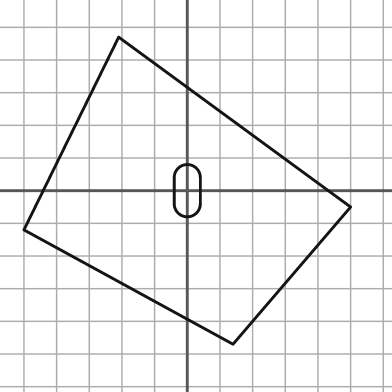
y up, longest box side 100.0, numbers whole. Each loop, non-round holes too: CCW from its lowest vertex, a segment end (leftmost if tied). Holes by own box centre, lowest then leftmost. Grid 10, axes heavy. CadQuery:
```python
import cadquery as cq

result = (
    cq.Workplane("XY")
    .moveTo(14.0, -47.0)
    .lineTo(50.0, -5.0)
    .lineTo(-21.0, 47.0)
    .lineTo(-50.0, -12.0)
    .close()
    .moveTo(-4.0, -4.0)
    .threePointArc((0.0, -8.0), (4.0, -4.0))
    .lineTo(4.0, 4.0)
    .threePointArc((0.0, 8.0), (-4.0, 4.0))
    .close()
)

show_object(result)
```